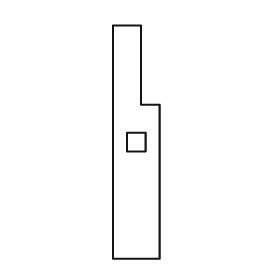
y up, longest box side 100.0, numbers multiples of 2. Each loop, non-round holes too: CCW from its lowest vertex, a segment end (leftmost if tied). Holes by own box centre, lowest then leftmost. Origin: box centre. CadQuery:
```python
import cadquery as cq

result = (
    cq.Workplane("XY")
    .moveTo(-10.0, -50.0)
    .lineTo(10.0, -50.0)
    .lineTo(10.0, 16.0)
    .lineTo(2.0, 16.0)
    .lineTo(2.0, 50.0)
    .lineTo(-10.0, 50.0)
    .close()
    .moveTo(-4.0, -4.0)
    .lineTo(4.0, -4.0)
    .lineTo(4.0, 4.0)
    .lineTo(-4.0, 4.0)
    .close()
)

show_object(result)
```